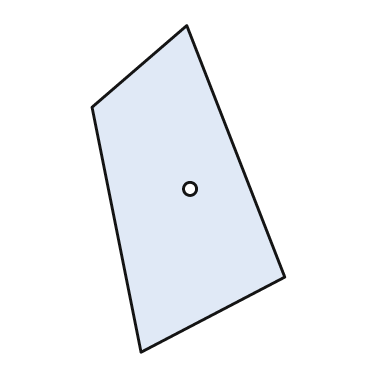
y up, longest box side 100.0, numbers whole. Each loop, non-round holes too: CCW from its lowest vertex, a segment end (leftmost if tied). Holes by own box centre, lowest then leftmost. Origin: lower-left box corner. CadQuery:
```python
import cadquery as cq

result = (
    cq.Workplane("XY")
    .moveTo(15.0, 0.0)
    .lineTo(59.0, 23.0)
    .lineTo(29.0, 100.0)
    .lineTo(0.0, 75.0)
    .close()
    .moveTo(30.0, 50.0)
    .circle(2.0)
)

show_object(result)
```